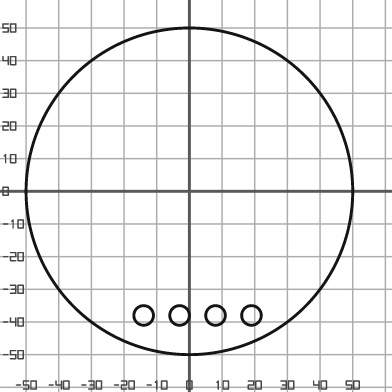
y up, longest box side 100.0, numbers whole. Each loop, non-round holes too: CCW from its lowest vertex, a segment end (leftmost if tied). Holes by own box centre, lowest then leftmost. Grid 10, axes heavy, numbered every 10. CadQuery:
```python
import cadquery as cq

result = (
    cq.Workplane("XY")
    .moveTo(0.0, 0.0)
    .circle(50.0)
    .moveTo(-14.0, -38.0)
    .circle(3.0)
    .moveTo(-3.0, -38.0)
    .circle(3.0)
    .moveTo(8.0, -38.0)
    .circle(3.0)
    .moveTo(19.0, -38.0)
    .circle(3.0)
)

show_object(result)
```